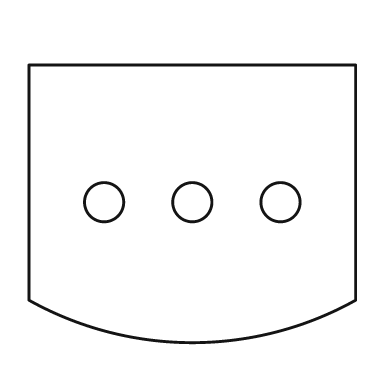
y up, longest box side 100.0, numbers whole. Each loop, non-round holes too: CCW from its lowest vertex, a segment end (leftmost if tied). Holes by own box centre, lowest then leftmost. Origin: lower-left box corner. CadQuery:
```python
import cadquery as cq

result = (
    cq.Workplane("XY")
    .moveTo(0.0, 13.0)
    .threePointArc((50.0, 0.0), (100.0, 13.0))
    .lineTo(100.0, 85.0)
    .lineTo(0.0, 85.0)
    .close()
    .moveTo(23.0, 43.0)
    .circle(6.0)
    .moveTo(50.0, 43.0)
    .circle(6.0)
    .moveTo(77.0, 43.0)
    .circle(6.0)
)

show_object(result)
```